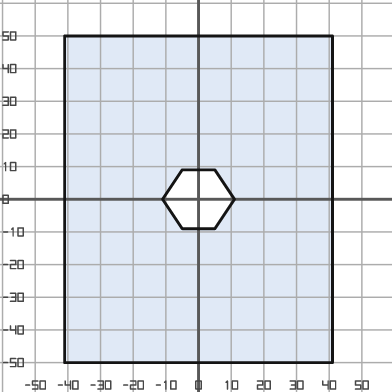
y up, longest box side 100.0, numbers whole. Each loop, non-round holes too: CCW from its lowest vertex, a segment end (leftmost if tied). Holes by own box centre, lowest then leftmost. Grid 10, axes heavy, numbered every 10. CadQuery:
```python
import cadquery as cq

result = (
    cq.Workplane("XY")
    .moveTo(-41.0, -50.0)
    .lineTo(41.0, -50.0)
    .lineTo(41.0, 50.0)
    .lineTo(-41.0, 50.0)
    .close()
    .moveTo(-5.0, -9.0)
    .lineTo(5.0, -9.0)
    .lineTo(11.0, 0.0)
    .lineTo(5.0, 9.0)
    .lineTo(-5.0, 9.0)
    .lineTo(-11.0, 0.0)
    .close()
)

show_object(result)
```